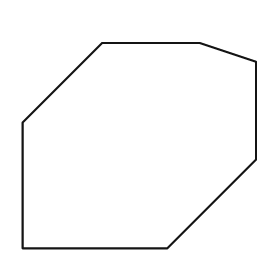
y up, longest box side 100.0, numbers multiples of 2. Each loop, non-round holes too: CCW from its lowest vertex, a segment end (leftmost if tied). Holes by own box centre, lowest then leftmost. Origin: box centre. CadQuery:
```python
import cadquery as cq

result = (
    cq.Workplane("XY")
    .moveTo(-50.0, -44.0)
    .lineTo(12.0, -44.0)
    .lineTo(50.0, -6.0)
    .lineTo(50.0, 36.0)
    .lineTo(26.0, 44.0)
    .lineTo(-16.0, 44.0)
    .lineTo(-50.0, 10.0)
    .close()
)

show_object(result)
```